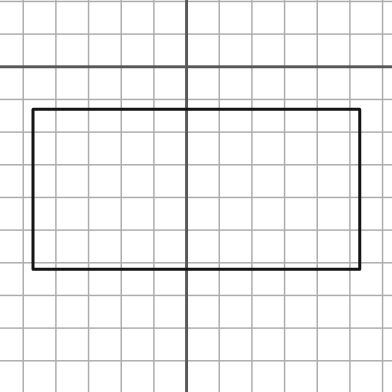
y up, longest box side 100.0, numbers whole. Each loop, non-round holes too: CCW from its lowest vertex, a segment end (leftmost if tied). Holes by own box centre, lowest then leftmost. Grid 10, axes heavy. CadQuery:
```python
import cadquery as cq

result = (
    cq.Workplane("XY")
    .moveTo(-47.0, -62.0)
    .lineTo(53.0, -62.0)
    .lineTo(53.0, -13.0)
    .lineTo(-47.0, -13.0)
    .close()
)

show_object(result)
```